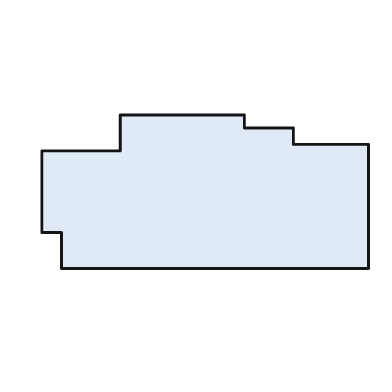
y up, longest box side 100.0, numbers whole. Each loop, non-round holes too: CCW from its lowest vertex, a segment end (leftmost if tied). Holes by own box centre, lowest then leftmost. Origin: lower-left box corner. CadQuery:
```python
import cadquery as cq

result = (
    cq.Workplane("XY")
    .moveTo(6.0, 0.0)
    .lineTo(100.0, 0.0)
    .lineTo(100.0, 38.0)
    .lineTo(77.0, 38.0)
    .lineTo(77.0, 43.0)
    .lineTo(62.0, 43.0)
    .lineTo(62.0, 47.0)
    .lineTo(24.0, 47.0)
    .lineTo(24.0, 36.0)
    .lineTo(0.0, 36.0)
    .lineTo(0.0, 11.0)
    .lineTo(6.0, 11.0)
    .close()
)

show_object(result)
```